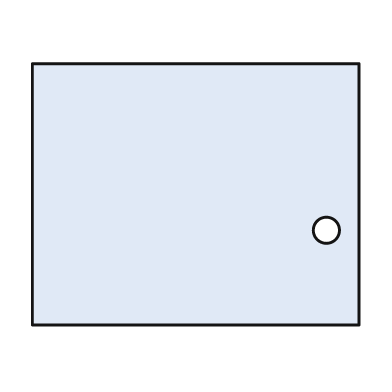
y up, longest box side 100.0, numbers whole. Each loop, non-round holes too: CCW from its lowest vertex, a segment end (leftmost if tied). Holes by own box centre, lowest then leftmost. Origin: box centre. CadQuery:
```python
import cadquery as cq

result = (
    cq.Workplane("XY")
    .moveTo(-50.0, -40.0)
    .lineTo(50.0, -40.0)
    .lineTo(50.0, 40.0)
    .lineTo(-50.0, 40.0)
    .close()
    .moveTo(40.0, -11.0)
    .circle(4.0)
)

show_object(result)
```